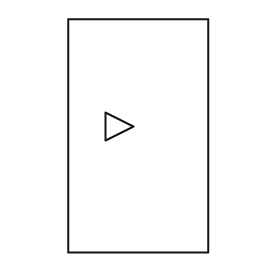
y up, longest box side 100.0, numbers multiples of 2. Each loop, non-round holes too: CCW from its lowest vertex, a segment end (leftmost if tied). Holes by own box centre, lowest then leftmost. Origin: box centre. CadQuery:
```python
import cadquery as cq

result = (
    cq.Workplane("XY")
    .moveTo(-30.0, -50.0)
    .lineTo(30.0, -50.0)
    .lineTo(30.0, 50.0)
    .lineTo(-30.0, 50.0)
    .close()
    .moveTo(-14.0, -2.0)
    .lineTo(-2.0, 4.0)
    .lineTo(-14.0, 10.0)
    .close()
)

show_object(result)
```